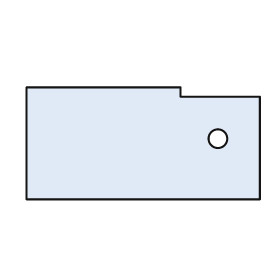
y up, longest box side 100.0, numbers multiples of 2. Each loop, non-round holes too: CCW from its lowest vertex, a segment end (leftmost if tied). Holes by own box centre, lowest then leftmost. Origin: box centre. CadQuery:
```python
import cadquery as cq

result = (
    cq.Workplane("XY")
    .moveTo(-50.0, -24.0)
    .lineTo(50.0, -24.0)
    .lineTo(50.0, 20.0)
    .lineTo(16.0, 20.0)
    .lineTo(16.0, 24.0)
    .lineTo(-50.0, 24.0)
    .close()
    .moveTo(32.0, 2.0)
    .circle(4.0)
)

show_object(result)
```